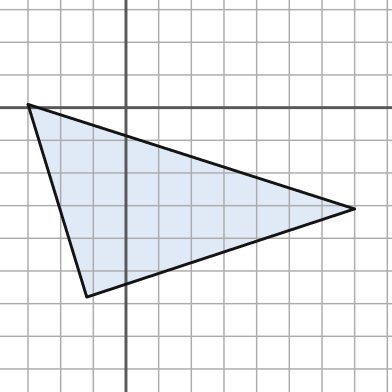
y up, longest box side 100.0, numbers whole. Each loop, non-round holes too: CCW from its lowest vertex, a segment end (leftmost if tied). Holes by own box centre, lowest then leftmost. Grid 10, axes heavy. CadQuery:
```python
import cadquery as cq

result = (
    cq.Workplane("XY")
    .moveTo(-12.0, -58.0)
    .lineTo(70.0, -31.0)
    .lineTo(-30.0, 1.0)
    .close()
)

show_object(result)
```